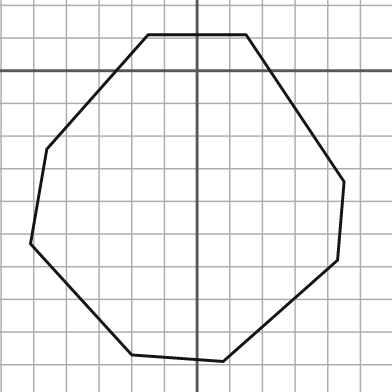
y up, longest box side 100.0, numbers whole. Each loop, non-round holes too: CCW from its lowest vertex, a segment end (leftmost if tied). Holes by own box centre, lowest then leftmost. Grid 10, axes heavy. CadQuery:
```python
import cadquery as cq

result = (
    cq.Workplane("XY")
    .moveTo(8.0, -89.0)
    .lineTo(43.0, -58.0)
    .lineTo(45.0, -34.0)
    .lineTo(15.0, 11.0)
    .lineTo(-15.0, 11.0)
    .lineTo(-46.0, -24.0)
    .lineTo(-51.0, -53.0)
    .lineTo(-20.0, -87.0)
    .close()
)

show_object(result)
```